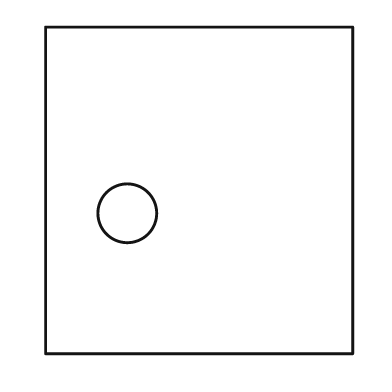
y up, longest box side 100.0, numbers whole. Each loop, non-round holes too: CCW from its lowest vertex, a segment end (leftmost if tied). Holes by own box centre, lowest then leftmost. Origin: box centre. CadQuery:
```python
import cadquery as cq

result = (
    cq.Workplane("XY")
    .moveTo(-47.0, -50.0)
    .lineTo(47.0, -50.0)
    .lineTo(47.0, 50.0)
    .lineTo(-47.0, 50.0)
    .close()
    .moveTo(-22.0, -7.0)
    .circle(9.0)
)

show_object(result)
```